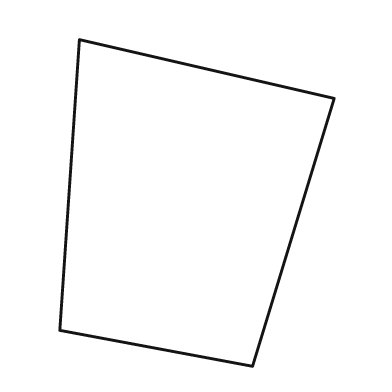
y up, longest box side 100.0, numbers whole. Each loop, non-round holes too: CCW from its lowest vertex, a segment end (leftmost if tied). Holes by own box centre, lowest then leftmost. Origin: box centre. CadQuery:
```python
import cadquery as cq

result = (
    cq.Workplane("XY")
    .moveTo(17.0, -50.0)
    .lineTo(42.0, 32.0)
    .lineTo(-36.0, 50.0)
    .lineTo(-42.0, -39.0)
    .close()
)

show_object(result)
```